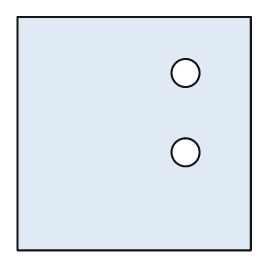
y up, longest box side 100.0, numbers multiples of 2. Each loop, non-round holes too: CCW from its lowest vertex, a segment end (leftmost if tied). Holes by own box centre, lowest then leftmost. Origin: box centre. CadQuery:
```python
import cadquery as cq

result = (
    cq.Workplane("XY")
    .moveTo(-50.0, -50.0)
    .lineTo(50.0, -50.0)
    .lineTo(50.0, 50.0)
    .lineTo(-50.0, 50.0)
    .close()
    .moveTo(22.0, -8.0)
    .circle(6.0)
    .moveTo(22.0, 26.0)
    .circle(6.0)
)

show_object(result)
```